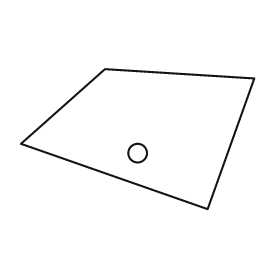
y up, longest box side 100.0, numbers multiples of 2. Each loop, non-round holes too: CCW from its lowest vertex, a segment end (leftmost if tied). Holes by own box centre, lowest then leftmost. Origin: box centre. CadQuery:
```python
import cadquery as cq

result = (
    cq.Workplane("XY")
    .moveTo(30.0, -30.0)
    .lineTo(50.0, 26.0)
    .lineTo(-14.0, 30.0)
    .lineTo(-50.0, -2.0)
    .close()
    .moveTo(0.0, -6.0)
    .circle(4.0)
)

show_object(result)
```